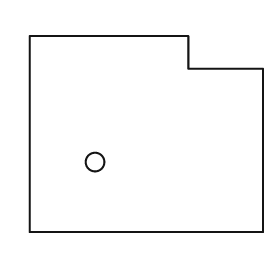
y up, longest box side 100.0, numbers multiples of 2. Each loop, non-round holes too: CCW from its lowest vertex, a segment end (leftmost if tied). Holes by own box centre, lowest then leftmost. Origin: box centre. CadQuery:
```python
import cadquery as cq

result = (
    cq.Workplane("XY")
    .moveTo(-50.0, -42.0)
    .lineTo(50.0, -42.0)
    .lineTo(50.0, 28.0)
    .lineTo(18.0, 28.0)
    .lineTo(18.0, 42.0)
    .lineTo(-50.0, 42.0)
    .close()
    .moveTo(-22.0, -12.0)
    .circle(4.0)
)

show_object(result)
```